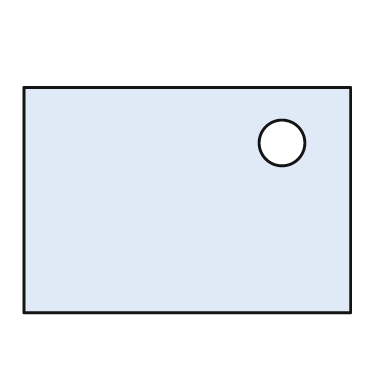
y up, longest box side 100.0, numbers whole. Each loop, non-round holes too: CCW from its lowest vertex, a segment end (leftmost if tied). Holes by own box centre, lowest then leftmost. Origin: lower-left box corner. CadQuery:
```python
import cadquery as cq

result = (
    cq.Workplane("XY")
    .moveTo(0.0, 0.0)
    .lineTo(100.0, 0.0)
    .lineTo(100.0, 69.0)
    .lineTo(0.0, 69.0)
    .close()
    .moveTo(79.0, 52.0)
    .circle(7.0)
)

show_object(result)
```